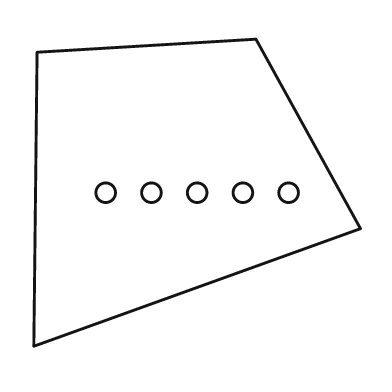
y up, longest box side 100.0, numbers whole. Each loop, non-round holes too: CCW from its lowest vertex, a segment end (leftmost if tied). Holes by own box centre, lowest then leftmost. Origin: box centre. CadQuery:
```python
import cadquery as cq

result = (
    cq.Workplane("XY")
    .moveTo(-50.0, -47.0)
    .lineTo(50.0, -11.0)
    .lineTo(18.0, 47.0)
    .lineTo(-49.0, 43.0)
    .close()
    .moveTo(-28.0, 0.0)
    .circle(3.0)
    .moveTo(-14.0, 0.0)
    .circle(3.0)
    .moveTo(0.0, 0.0)
    .circle(3.0)
    .moveTo(14.0, 0.0)
    .circle(3.0)
    .moveTo(28.0, 0.0)
    .circle(3.0)
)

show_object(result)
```